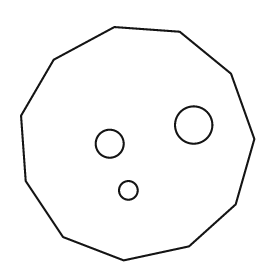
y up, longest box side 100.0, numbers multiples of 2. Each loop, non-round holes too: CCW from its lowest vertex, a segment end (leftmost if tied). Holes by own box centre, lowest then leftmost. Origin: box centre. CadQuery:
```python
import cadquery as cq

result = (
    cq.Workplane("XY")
    .moveTo(-6.0, -50.0)
    .lineTo(22.0, -44.0)
    .lineTo(42.0, -26.0)
    .lineTo(50.0, 2.0)
    .lineTo(40.0, 30.0)
    .lineTo(18.0, 48.0)
    .lineTo(-10.0, 50.0)
    .lineTo(-36.0, 36.0)
    .lineTo(-50.0, 12.0)
    .lineTo(-48.0, -16.0)
    .lineTo(-32.0, -40.0)
    .close()
    .moveTo(-4.0, -20.0)
    .circle(4.0)
    .moveTo(-12.0, 0.0)
    .circle(6.0)
    .moveTo(24.0, 8.0)
    .circle(8.0)
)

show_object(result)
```